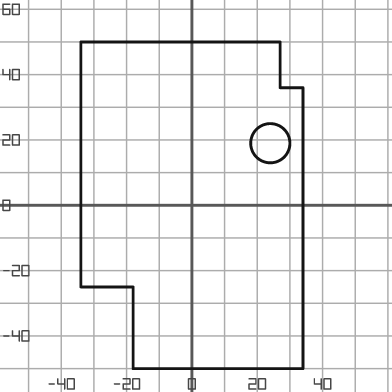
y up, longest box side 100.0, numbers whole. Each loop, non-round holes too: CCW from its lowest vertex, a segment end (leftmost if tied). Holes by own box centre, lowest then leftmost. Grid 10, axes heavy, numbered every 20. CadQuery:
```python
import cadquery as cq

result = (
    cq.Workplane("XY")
    .moveTo(-18.0, -50.0)
    .lineTo(34.0, -50.0)
    .lineTo(34.0, 36.0)
    .lineTo(27.0, 36.0)
    .lineTo(27.0, 50.0)
    .lineTo(-34.0, 50.0)
    .lineTo(-34.0, -25.0)
    .lineTo(-18.0, -25.0)
    .close()
    .moveTo(24.0, 19.0)
    .circle(6.0)
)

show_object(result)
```